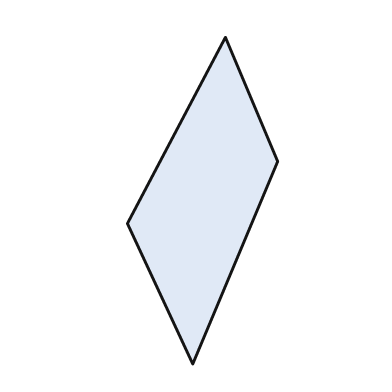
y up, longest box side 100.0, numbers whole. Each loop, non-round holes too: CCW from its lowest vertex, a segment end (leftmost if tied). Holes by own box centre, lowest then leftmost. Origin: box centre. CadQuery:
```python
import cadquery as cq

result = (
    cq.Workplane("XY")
    .moveTo(-3.0, -50.0)
    .lineTo(23.0, 12.0)
    .lineTo(7.0, 50.0)
    .lineTo(-23.0, -7.0)
    .close()
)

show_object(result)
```